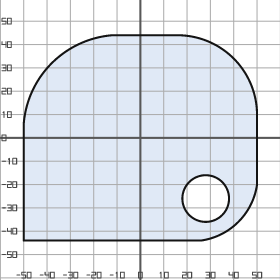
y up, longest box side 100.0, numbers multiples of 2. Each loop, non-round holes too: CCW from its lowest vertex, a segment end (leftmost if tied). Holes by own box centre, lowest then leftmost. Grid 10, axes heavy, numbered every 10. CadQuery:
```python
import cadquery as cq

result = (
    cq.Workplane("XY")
    .moveTo(-50.0, -44.0)
    .lineTo(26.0, -44.0)
    .threePointArc((42.0, -36.0), (50.0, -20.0))
    .lineTo(50.0, 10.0)
    .threePointArc((40.0, 34.0), (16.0, 44.0))
    .lineTo(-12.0, 44.0)
    .threePointArc((-38.0, 32.0), (-50.0, 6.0))
    .close()
    .moveTo(28.0, -26.0)
    .circle(10.0)
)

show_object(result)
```